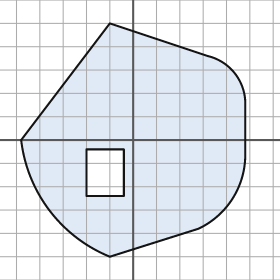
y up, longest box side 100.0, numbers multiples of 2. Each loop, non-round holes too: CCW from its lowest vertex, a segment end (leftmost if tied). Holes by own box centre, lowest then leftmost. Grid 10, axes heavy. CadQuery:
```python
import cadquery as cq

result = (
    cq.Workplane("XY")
    .moveTo(-10.0, -50.0)
    .lineTo(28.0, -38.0)
    .threePointArc((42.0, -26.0), (48.0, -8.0))
    .lineTo(48.0, 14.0)
    .threePointArc((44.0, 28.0), (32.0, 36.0))
    .lineTo(-10.0, 50.0)
    .lineTo(-48.0, 0.0)
    .threePointArc((-36.0, -30.0), (-10.0, -50.0))
    .close()
    .moveTo(-20.0, -24.0)
    .lineTo(-4.0, -24.0)
    .lineTo(-4.0, -4.0)
    .lineTo(-20.0, -4.0)
    .close()
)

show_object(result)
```